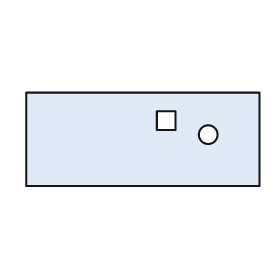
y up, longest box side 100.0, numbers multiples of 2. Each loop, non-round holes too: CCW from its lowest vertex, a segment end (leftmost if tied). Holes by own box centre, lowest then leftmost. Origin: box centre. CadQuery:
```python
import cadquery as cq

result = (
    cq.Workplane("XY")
    .moveTo(-50.0, -20.0)
    .lineTo(50.0, -20.0)
    .lineTo(50.0, 20.0)
    .lineTo(-50.0, 20.0)
    .close()
    .moveTo(28.0, 2.0)
    .circle(4.0)
    .moveTo(6.0, 4.0)
    .lineTo(14.0, 4.0)
    .lineTo(14.0, 12.0)
    .lineTo(6.0, 12.0)
    .close()
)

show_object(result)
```